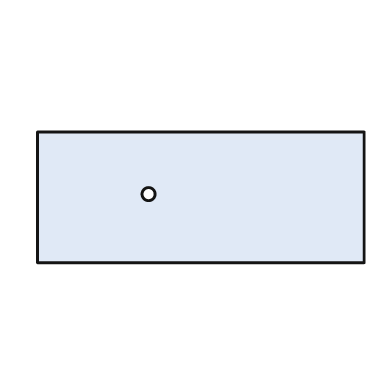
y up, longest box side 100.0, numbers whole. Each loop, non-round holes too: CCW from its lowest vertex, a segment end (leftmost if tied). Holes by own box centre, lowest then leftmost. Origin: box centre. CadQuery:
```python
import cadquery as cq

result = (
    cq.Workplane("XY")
    .moveTo(-50.0, -20.0)
    .lineTo(50.0, -20.0)
    .lineTo(50.0, 20.0)
    .lineTo(-50.0, 20.0)
    .close()
    .moveTo(-16.0, 1.0)
    .circle(2.0)
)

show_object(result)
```